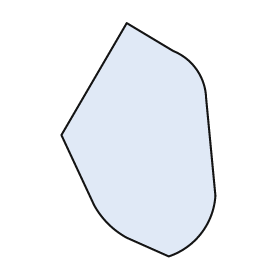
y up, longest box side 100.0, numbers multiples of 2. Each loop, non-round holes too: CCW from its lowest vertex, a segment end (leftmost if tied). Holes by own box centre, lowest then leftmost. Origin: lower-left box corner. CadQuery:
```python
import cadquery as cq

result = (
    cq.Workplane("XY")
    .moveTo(46.0, 0.0)
    .threePointArc((60.0, 10.0), (66.0, 26.0))
    .lineTo(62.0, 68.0)
    .threePointArc((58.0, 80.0), (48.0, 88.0))
    .lineTo(28.0, 100.0)
    .lineTo(0.0, 52.0)
    .lineTo(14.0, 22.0)
    .threePointArc((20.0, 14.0), (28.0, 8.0))
    .close()
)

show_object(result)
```